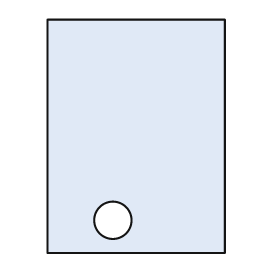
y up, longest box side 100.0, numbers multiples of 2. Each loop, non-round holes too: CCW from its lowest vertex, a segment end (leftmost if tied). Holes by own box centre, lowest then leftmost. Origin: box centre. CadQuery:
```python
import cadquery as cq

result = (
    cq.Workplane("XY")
    .moveTo(-38.0, -50.0)
    .lineTo(38.0, -50.0)
    .lineTo(38.0, 50.0)
    .lineTo(-38.0, 50.0)
    .close()
    .moveTo(-10.0, -36.0)
    .circle(8.0)
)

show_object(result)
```